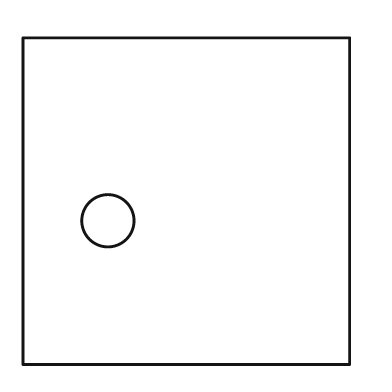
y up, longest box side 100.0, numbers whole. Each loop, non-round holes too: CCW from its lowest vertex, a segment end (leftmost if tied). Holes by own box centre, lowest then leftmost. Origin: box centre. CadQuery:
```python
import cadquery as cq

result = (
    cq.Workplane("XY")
    .moveTo(-50.0, -50.0)
    .lineTo(50.0, -50.0)
    .lineTo(50.0, 50.0)
    .lineTo(-50.0, 50.0)
    .close()
    .moveTo(-24.0, -6.0)
    .circle(8.0)
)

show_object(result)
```